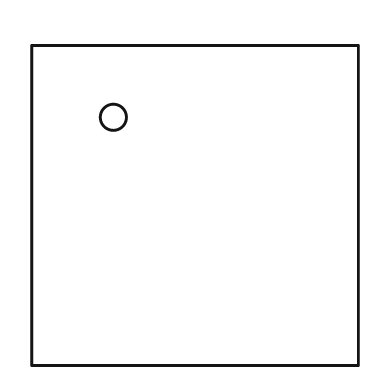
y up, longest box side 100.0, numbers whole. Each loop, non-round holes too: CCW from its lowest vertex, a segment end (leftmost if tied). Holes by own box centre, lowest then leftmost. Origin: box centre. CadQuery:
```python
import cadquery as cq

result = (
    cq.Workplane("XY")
    .moveTo(-50.0, -49.0)
    .lineTo(50.0, -49.0)
    .lineTo(50.0, 49.0)
    .lineTo(-50.0, 49.0)
    .close()
    .moveTo(-25.0, 27.0)
    .circle(4.0)
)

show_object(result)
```